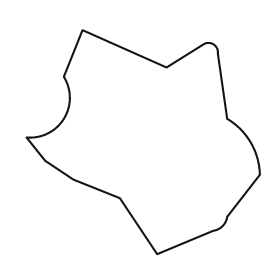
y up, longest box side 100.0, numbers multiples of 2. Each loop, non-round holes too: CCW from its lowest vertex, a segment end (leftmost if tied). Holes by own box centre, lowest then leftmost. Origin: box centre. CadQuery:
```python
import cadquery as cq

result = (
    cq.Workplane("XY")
    .moveTo(6.0, -48.0)
    .lineTo(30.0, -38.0)
    .threePointArc((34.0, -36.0), (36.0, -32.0))
    .lineTo(50.0, -14.0)
    .threePointArc((46.0, 0.0), (36.0, 10.0))
    .lineTo(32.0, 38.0)
    .threePointArc((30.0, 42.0), (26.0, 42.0))
    .lineTo(10.0, 32.0)
    .lineTo(-26.0, 48.0)
    .lineTo(-34.0, 28.0)
    .threePointArc((-34.0, 10.0), (-50.0, 2.0))
    .lineTo(-42.0, -8.0)
    .lineTo(-30.0, -16.0)
    .lineTo(-10.0, -24.0)
    .close()
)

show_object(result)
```